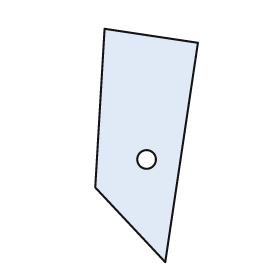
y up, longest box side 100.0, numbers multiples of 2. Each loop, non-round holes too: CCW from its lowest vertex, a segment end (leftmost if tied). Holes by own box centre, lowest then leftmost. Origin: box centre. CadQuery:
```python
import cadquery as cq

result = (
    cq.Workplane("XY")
    .moveTo(8.0, -50.0)
    .lineTo(22.0, 44.0)
    .lineTo(-18.0, 50.0)
    .lineTo(-22.0, -18.0)
    .close()
    .moveTo(0.0, -6.0)
    .circle(4.0)
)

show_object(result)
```